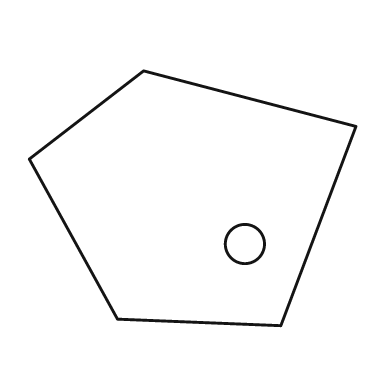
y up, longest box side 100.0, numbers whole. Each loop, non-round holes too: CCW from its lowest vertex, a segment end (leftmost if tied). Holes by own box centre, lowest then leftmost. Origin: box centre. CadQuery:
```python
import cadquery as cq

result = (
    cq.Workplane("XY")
    .moveTo(27.0, -39.0)
    .lineTo(50.0, 22.0)
    .lineTo(-15.0, 39.0)
    .lineTo(-50.0, 12.0)
    .lineTo(-23.0, -37.0)
    .close()
    .moveTo(16.0, -14.0)
    .circle(6.0)
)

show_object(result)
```